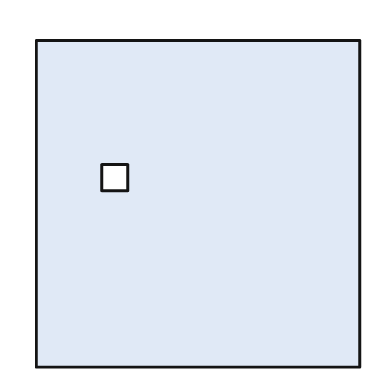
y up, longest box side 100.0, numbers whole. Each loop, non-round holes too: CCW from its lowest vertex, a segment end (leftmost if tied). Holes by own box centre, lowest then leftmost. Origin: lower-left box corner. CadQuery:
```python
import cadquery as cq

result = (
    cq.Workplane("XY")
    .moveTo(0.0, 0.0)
    .lineTo(99.0, 0.0)
    .lineTo(99.0, 100.0)
    .lineTo(0.0, 100.0)
    .close()
    .moveTo(20.0, 54.0)
    .lineTo(28.0, 54.0)
    .lineTo(28.0, 62.0)
    .lineTo(20.0, 62.0)
    .close()
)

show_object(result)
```